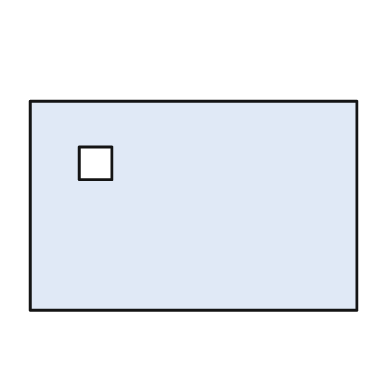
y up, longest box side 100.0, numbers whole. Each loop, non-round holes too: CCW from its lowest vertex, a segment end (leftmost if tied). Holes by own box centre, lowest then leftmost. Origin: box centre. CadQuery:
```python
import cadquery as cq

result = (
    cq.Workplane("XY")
    .moveTo(-50.0, -32.0)
    .lineTo(50.0, -32.0)
    .lineTo(50.0, 32.0)
    .lineTo(-50.0, 32.0)
    .close()
    .moveTo(-35.0, 8.0)
    .lineTo(-25.0, 8.0)
    .lineTo(-25.0, 18.0)
    .lineTo(-35.0, 18.0)
    .close()
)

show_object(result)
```